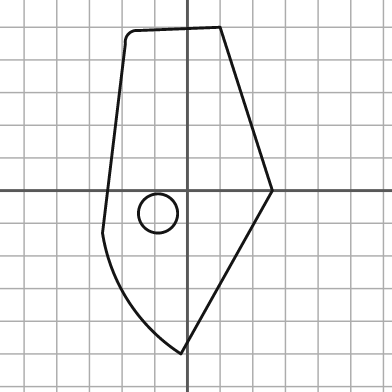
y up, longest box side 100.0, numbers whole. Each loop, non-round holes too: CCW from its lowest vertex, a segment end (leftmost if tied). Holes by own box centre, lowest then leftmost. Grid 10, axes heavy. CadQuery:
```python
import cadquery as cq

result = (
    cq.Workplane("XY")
    .moveTo(-2.0, -50.0)
    .lineTo(26.0, 0.0)
    .lineTo(10.0, 50.0)
    .lineTo(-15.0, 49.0)
    .threePointArc((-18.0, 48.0), (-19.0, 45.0))
    .lineTo(-26.0, -13.0)
    .threePointArc((-18.0, -34.0), (-2.0, -50.0))
    .close()
    .moveTo(-9.0, -7.0)
    .circle(6.0)
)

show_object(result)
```